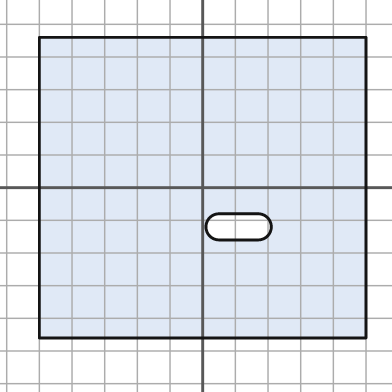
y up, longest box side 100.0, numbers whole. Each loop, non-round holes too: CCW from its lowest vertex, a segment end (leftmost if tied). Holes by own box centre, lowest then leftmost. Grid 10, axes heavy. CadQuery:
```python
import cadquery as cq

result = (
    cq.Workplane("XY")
    .moveTo(-50.0, -46.0)
    .lineTo(50.0, -46.0)
    .lineTo(50.0, 46.0)
    .lineTo(-50.0, 46.0)
    .close()
    .moveTo(5.0, -16.0)
    .lineTo(17.0, -16.0)
    .threePointArc((21.0, -12.0), (17.0, -8.0))
    .lineTo(5.0, -8.0)
    .threePointArc((1.0, -12.0), (5.0, -16.0))
    .close()
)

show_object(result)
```